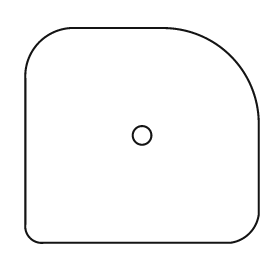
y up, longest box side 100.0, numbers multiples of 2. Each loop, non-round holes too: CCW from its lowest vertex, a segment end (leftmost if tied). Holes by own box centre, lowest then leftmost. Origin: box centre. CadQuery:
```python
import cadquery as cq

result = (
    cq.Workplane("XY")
    .moveTo(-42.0, -46.0)
    .lineTo(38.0, -46.0)
    .threePointArc((46.0, -42.0), (50.0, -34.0))
    .lineTo(50.0, 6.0)
    .threePointArc((38.0, 34.0), (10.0, 46.0))
    .lineTo(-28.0, 46.0)
    .threePointArc((-44.0, 40.0), (-50.0, 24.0))
    .lineTo(-50.0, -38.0)
    .threePointArc((-48.0, -44.0), (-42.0, -46.0))
    .close()
    .moveTo(0.0, 0.0)
    .circle(4.0)
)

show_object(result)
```